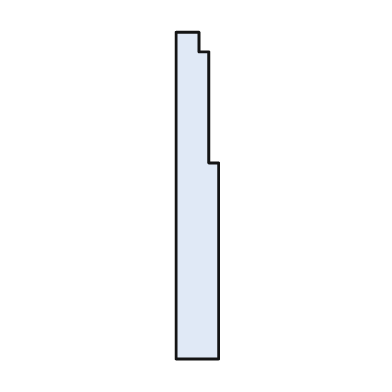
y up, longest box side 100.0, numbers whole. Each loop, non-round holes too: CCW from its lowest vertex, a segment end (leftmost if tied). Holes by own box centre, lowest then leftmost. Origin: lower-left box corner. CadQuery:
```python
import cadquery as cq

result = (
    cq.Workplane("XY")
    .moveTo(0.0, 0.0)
    .lineTo(13.0, 0.0)
    .lineTo(13.0, 60.0)
    .lineTo(10.0, 60.0)
    .lineTo(10.0, 94.0)
    .lineTo(7.0, 94.0)
    .lineTo(7.0, 100.0)
    .lineTo(0.0, 100.0)
    .close()
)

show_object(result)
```